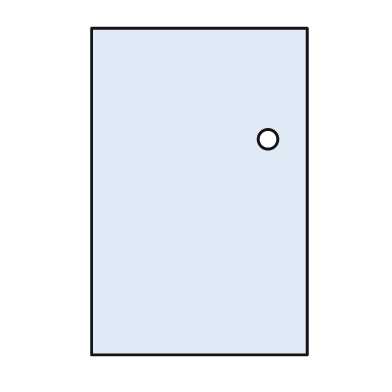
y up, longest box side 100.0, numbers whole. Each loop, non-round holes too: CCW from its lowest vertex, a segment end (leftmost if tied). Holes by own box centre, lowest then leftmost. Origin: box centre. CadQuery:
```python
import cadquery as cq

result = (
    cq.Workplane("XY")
    .moveTo(-33.0, -50.0)
    .lineTo(33.0, -50.0)
    .lineTo(33.0, 50.0)
    .lineTo(-33.0, 50.0)
    .close()
    .moveTo(21.0, 16.0)
    .circle(3.0)
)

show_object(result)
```